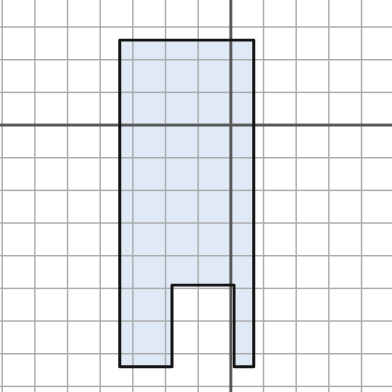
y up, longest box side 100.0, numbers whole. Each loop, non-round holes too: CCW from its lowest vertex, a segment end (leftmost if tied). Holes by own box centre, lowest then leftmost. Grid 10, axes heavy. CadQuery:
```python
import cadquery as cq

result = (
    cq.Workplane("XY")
    .moveTo(-34.0, -74.0)
    .lineTo(-18.0, -74.0)
    .lineTo(-18.0, -49.0)
    .lineTo(1.0, -49.0)
    .lineTo(1.0, -74.0)
    .lineTo(7.0, -74.0)
    .lineTo(7.0, 26.0)
    .lineTo(-34.0, 26.0)
    .close()
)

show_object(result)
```